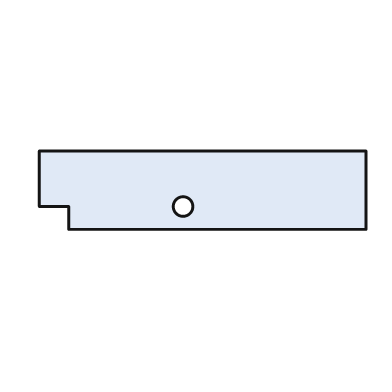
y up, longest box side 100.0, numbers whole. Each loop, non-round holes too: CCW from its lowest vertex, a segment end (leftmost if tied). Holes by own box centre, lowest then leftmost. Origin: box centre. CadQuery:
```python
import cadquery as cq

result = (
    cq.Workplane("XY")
    .moveTo(-41.0, -12.0)
    .lineTo(50.0, -12.0)
    .lineTo(50.0, 12.0)
    .lineTo(-50.0, 12.0)
    .lineTo(-50.0, -5.0)
    .lineTo(-41.0, -5.0)
    .close()
    .moveTo(-6.0, -5.0)
    .circle(3.0)
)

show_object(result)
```